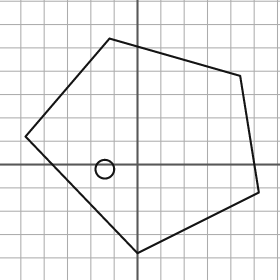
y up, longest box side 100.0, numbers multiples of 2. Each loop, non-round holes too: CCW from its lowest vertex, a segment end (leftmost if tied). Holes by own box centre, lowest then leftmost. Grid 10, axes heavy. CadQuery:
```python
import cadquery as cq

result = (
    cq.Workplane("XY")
    .moveTo(0.0, -38.0)
    .lineTo(52.0, -12.0)
    .lineTo(44.0, 38.0)
    .lineTo(-12.0, 54.0)
    .lineTo(-48.0, 12.0)
    .close()
    .moveTo(-14.0, -2.0)
    .circle(4.0)
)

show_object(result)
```